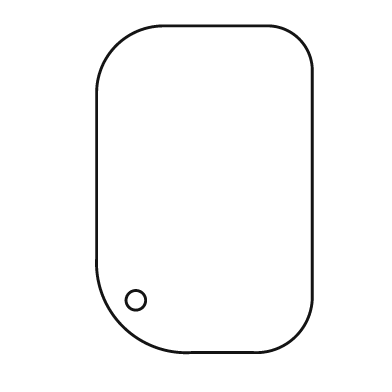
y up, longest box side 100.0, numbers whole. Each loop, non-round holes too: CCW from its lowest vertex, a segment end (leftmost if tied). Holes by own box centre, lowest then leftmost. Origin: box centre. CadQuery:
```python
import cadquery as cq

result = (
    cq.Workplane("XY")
    .moveTo(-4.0, -50.0)
    .lineTo(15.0, -50.0)
    .threePointArc((28.0, -45.0), (33.0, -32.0))
    .lineTo(33.0, 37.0)
    .threePointArc((29.0, 46.0), (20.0, 50.0))
    .lineTo(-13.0, 50.0)
    .threePointArc((-27.0, 44.0), (-33.0, 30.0))
    .lineTo(-33.0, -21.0)
    .threePointArc((-25.0, -42.0), (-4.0, -50.0))
    .close()
    .moveTo(-21.0, -34.0)
    .circle(3.0)
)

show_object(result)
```